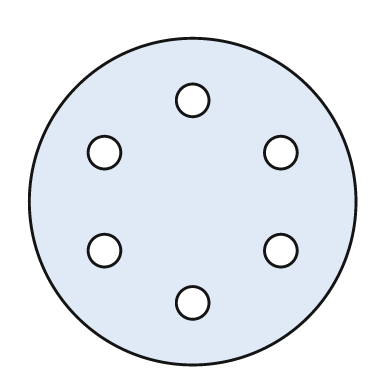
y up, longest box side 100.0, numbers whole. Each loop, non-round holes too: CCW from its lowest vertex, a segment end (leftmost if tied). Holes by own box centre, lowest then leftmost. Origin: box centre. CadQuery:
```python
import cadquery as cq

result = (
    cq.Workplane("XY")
    .moveTo(0.0, 0.0)
    .circle(50.0)
    .moveTo(0.0, -31.0)
    .circle(5.0)
    .moveTo(-27.0, -15.0)
    .circle(5.0)
    .moveTo(27.0, -15.0)
    .circle(5.0)
    .moveTo(-27.0, 15.0)
    .circle(5.0)
    .moveTo(27.0, 15.0)
    .circle(5.0)
    .moveTo(0.0, 31.0)
    .circle(5.0)
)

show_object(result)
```